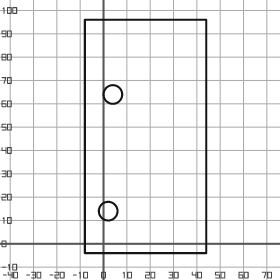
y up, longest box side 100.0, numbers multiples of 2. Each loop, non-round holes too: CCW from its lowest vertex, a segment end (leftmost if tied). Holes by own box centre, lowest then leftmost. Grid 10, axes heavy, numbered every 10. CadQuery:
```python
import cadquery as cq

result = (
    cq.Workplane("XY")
    .moveTo(-8.0, -4.0)
    .lineTo(44.0, -4.0)
    .lineTo(44.0, 96.0)
    .lineTo(-8.0, 96.0)
    .close()
    .moveTo(2.0, 14.0)
    .circle(4.0)
    .moveTo(4.0, 64.0)
    .circle(4.0)
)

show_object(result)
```